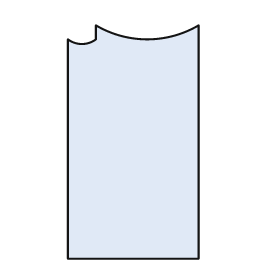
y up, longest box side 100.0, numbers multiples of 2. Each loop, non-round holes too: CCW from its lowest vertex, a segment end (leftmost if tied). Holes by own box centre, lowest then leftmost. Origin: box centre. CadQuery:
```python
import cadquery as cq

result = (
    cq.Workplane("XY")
    .moveTo(-28.0, -50.0)
    .lineTo(28.0, -50.0)
    .lineTo(28.0, 50.0)
    .threePointArc((6.0, 44.0), (-16.0, 50.0))
    .lineTo(-16.0, 44.0)
    .threePointArc((-22.0, 42.0), (-28.0, 44.0))
    .close()
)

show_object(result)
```